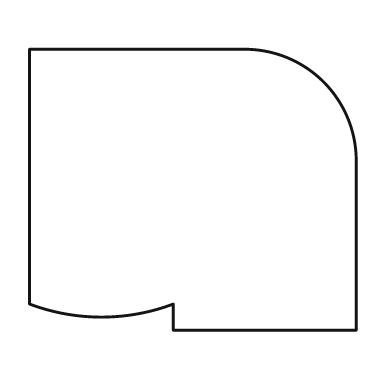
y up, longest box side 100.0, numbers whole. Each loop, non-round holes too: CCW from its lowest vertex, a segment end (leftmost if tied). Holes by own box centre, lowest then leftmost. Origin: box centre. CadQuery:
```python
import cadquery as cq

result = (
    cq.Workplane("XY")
    .moveTo(-6.0, -43.0)
    .lineTo(50.0, -43.0)
    .lineTo(50.0, 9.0)
    .threePointArc((40.0, 33.0), (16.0, 43.0))
    .lineTo(-50.0, 43.0)
    .lineTo(-50.0, -35.0)
    .threePointArc((-28.0, -39.0), (-6.0, -35.0))
    .close()
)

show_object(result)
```